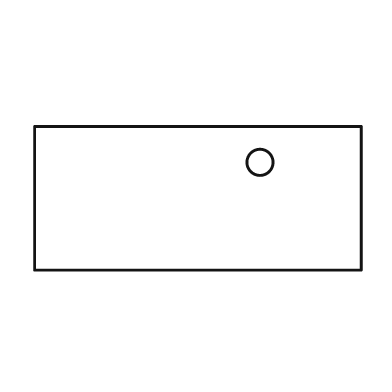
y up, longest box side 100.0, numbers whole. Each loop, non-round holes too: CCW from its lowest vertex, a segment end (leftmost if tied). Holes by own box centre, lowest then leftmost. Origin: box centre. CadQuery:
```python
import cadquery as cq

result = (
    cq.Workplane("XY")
    .moveTo(-50.0, -22.0)
    .lineTo(50.0, -22.0)
    .lineTo(50.0, 22.0)
    .lineTo(-50.0, 22.0)
    .close()
    .moveTo(19.0, 11.0)
    .circle(4.0)
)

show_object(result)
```